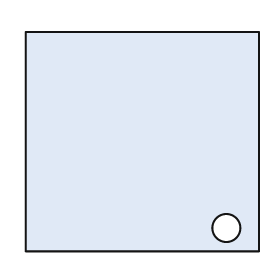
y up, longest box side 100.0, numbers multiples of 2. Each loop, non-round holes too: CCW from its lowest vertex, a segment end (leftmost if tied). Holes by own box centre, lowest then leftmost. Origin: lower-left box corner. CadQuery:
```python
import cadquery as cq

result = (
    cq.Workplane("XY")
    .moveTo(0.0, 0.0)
    .lineTo(100.0, 0.0)
    .lineTo(100.0, 94.0)
    .lineTo(0.0, 94.0)
    .close()
    .moveTo(86.0, 10.0)
    .circle(6.0)
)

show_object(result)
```